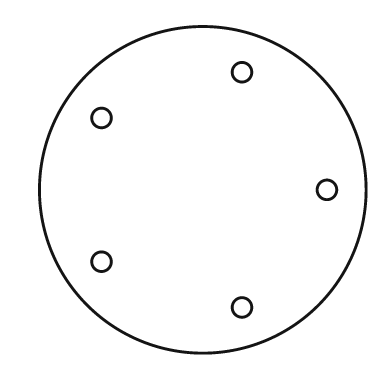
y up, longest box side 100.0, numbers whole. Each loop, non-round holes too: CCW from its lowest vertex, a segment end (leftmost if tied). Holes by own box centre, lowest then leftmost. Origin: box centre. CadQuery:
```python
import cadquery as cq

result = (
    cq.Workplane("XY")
    .moveTo(0.0, 0.0)
    .circle(50.0)
    .moveTo(12.0, -36.0)
    .circle(3.0)
    .moveTo(-31.0, -22.0)
    .circle(3.0)
    .moveTo(38.0, 0.0)
    .circle(3.0)
    .moveTo(-31.0, 22.0)
    .circle(3.0)
    .moveTo(12.0, 36.0)
    .circle(3.0)
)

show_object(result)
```